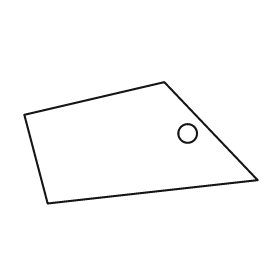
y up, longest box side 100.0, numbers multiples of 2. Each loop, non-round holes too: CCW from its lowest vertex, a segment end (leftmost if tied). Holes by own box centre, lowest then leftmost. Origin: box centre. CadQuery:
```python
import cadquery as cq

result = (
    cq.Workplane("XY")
    .moveTo(-40.0, -26.0)
    .lineTo(50.0, -16.0)
    .lineTo(10.0, 26.0)
    .lineTo(-50.0, 12.0)
    .close()
    .moveTo(20.0, 4.0)
    .circle(4.0)
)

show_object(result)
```